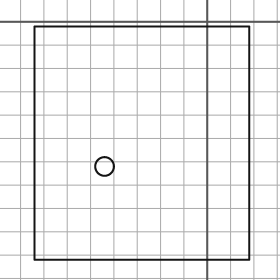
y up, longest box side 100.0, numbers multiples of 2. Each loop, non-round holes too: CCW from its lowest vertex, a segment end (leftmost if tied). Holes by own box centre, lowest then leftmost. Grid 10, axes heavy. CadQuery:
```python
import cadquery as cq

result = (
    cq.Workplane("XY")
    .moveTo(-74.0, -102.0)
    .lineTo(18.0, -102.0)
    .lineTo(18.0, -2.0)
    .lineTo(-74.0, -2.0)
    .close()
    .moveTo(-44.0, -62.0)
    .circle(4.0)
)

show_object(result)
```